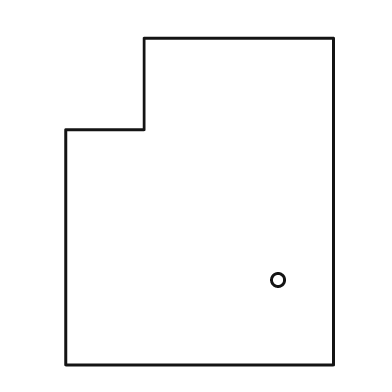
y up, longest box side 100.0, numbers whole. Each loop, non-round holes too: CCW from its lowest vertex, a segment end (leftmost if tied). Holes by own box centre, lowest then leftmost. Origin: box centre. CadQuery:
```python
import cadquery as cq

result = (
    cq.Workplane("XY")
    .moveTo(-41.0, -50.0)
    .lineTo(41.0, -50.0)
    .lineTo(41.0, 50.0)
    .lineTo(-17.0, 50.0)
    .lineTo(-17.0, 22.0)
    .lineTo(-41.0, 22.0)
    .close()
    .moveTo(24.0, -24.0)
    .circle(2.0)
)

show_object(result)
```